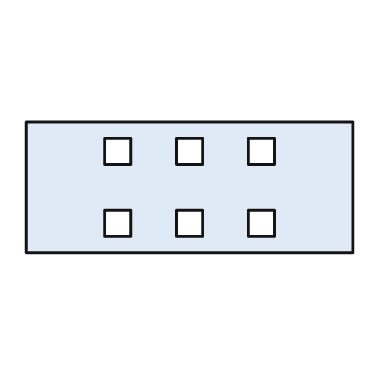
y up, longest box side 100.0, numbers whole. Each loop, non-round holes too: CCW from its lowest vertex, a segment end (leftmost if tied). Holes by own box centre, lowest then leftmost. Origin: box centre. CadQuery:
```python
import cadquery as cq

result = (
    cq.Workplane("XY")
    .moveTo(-50.0, -20.0)
    .lineTo(50.0, -20.0)
    .lineTo(50.0, 20.0)
    .lineTo(-50.0, 20.0)
    .close()
    .moveTo(-26.0, -15.0)
    .lineTo(-18.0, -15.0)
    .lineTo(-18.0, -7.0)
    .lineTo(-26.0, -7.0)
    .close()
    .moveTo(-4.0, -15.0)
    .lineTo(4.0, -15.0)
    .lineTo(4.0, -7.0)
    .lineTo(-4.0, -7.0)
    .close()
    .moveTo(18.0, -15.0)
    .lineTo(26.0, -15.0)
    .lineTo(26.0, -7.0)
    .lineTo(18.0, -7.0)
    .close()
    .moveTo(-26.0, 7.0)
    .lineTo(-18.0, 7.0)
    .lineTo(-18.0, 15.0)
    .lineTo(-26.0, 15.0)
    .close()
    .moveTo(-4.0, 7.0)
    .lineTo(4.0, 7.0)
    .lineTo(4.0, 15.0)
    .lineTo(-4.0, 15.0)
    .close()
    .moveTo(18.0, 7.0)
    .lineTo(26.0, 7.0)
    .lineTo(26.0, 15.0)
    .lineTo(18.0, 15.0)
    .close()
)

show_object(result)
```